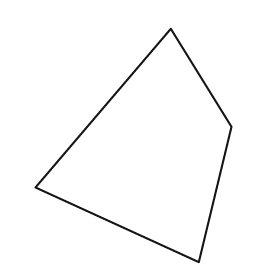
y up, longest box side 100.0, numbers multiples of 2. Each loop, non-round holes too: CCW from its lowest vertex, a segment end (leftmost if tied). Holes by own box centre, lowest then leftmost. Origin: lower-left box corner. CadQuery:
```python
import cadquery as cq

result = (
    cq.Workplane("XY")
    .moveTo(70.0, 0.0)
    .lineTo(84.0, 58.0)
    .lineTo(58.0, 100.0)
    .lineTo(0.0, 32.0)
    .close()
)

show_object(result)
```